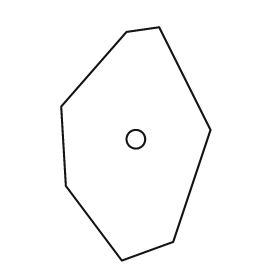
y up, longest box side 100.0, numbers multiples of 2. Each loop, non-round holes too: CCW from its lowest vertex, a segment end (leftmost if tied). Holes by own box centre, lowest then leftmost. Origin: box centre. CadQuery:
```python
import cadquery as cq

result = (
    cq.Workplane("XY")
    .moveTo(-6.0, -50.0)
    .lineTo(16.0, -42.0)
    .lineTo(32.0, 6.0)
    .lineTo(10.0, 50.0)
    .lineTo(-4.0, 48.0)
    .lineTo(-32.0, 16.0)
    .lineTo(-30.0, -18.0)
    .close()
    .moveTo(0.0, 2.0)
    .circle(4.0)
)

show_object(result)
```